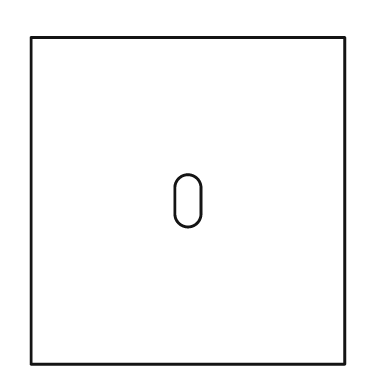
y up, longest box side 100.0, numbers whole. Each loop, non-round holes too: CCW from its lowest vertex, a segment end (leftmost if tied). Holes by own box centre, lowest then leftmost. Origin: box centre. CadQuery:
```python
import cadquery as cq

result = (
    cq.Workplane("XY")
    .moveTo(-48.0, -50.0)
    .lineTo(48.0, -50.0)
    .lineTo(48.0, 50.0)
    .lineTo(-48.0, 50.0)
    .close()
    .moveTo(-4.0, -4.0)
    .threePointArc((0.0, -8.0), (4.0, -4.0))
    .lineTo(4.0, 4.0)
    .threePointArc((0.0, 8.0), (-4.0, 4.0))
    .close()
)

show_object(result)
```